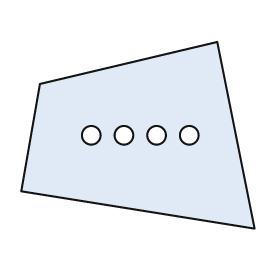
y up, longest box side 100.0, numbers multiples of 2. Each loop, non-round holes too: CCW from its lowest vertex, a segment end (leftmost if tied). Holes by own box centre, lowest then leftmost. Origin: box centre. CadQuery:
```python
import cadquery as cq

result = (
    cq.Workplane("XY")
    .moveTo(50.0, -40.0)
    .lineTo(34.0, 40.0)
    .lineTo(-42.0, 22.0)
    .lineTo(-50.0, -24.0)
    .close()
    .moveTo(-20.0, 0.0)
    .circle(4.0)
    .moveTo(-6.0, 0.0)
    .circle(4.0)
    .moveTo(8.0, 0.0)
    .circle(4.0)
    .moveTo(22.0, 0.0)
    .circle(4.0)
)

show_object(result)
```